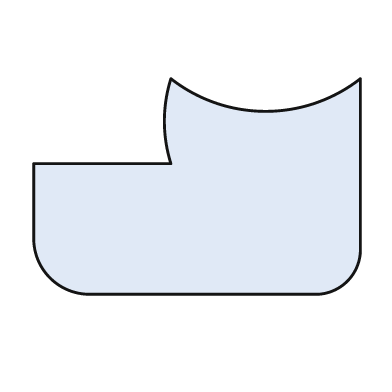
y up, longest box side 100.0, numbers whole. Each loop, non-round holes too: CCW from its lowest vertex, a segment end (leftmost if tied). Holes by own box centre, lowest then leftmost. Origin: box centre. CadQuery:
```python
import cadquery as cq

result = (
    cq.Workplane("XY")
    .moveTo(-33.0, -33.0)
    .lineTo(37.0, -33.0)
    .threePointArc((46.0, -29.0), (50.0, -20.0))
    .lineTo(50.0, 33.0)
    .threePointArc((21.0, 23.0), (-8.0, 33.0))
    .threePointArc((-10.0, 20.0), (-8.0, 7.0))
    .lineTo(-50.0, 7.0)
    .lineTo(-50.0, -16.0)
    .threePointArc((-45.0, -28.0), (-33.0, -33.0))
    .close()
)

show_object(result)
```